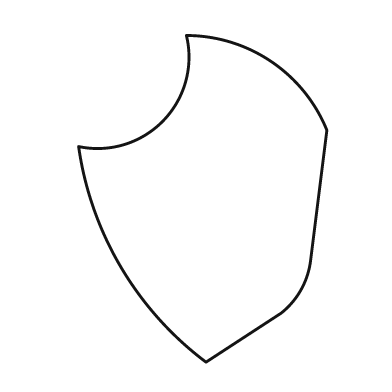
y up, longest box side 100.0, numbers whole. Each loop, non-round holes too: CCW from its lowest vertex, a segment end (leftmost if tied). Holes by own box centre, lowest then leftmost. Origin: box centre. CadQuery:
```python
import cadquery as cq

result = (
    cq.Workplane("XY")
    .moveTo(1.0, -50.0)
    .lineTo(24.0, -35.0)
    .threePointArc((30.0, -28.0), (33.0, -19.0))
    .lineTo(38.0, 21.0)
    .threePointArc((21.0, 42.0), (-5.0, 50.0))
    .threePointArc((-12.0, 24.0), (-38.0, 16.0))
    .threePointArc((-25.0, -21.0), (1.0, -50.0))
    .close()
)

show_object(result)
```